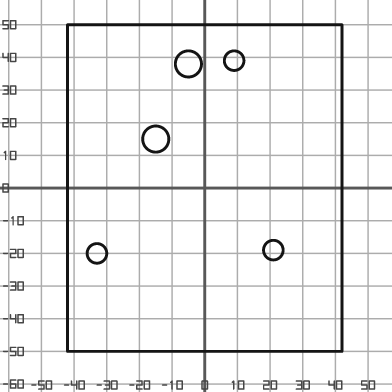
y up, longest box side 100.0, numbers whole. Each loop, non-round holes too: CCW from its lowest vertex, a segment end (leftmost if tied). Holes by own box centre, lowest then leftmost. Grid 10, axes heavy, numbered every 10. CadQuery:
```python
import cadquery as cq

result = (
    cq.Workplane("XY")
    .moveTo(-42.0, -50.0)
    .lineTo(42.0, -50.0)
    .lineTo(42.0, 50.0)
    .lineTo(-42.0, 50.0)
    .close()
    .moveTo(-33.0, -20.0)
    .circle(3.0)
    .moveTo(21.0, -19.0)
    .circle(3.0)
    .moveTo(-15.0, 15.0)
    .circle(4.0)
    .moveTo(-5.0, 38.0)
    .circle(4.0)
    .moveTo(9.0, 39.0)
    .circle(3.0)
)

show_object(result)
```